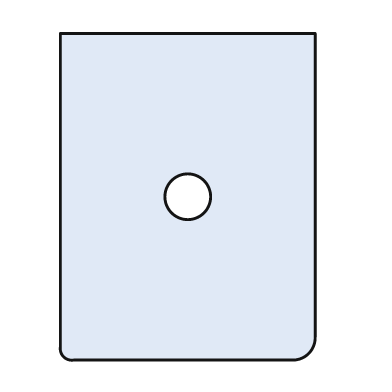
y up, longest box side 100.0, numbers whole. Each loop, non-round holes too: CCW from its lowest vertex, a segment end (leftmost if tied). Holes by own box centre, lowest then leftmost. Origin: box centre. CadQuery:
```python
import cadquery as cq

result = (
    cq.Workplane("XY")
    .moveTo(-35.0, -50.0)
    .lineTo(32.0, -50.0)
    .threePointArc((37.0, -48.0), (39.0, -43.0))
    .lineTo(39.0, 50.0)
    .lineTo(-39.0, 50.0)
    .lineTo(-39.0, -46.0)
    .threePointArc((-38.0, -49.0), (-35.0, -50.0))
    .close()
    .moveTo(0.0, 0.0)
    .circle(7.0)
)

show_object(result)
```